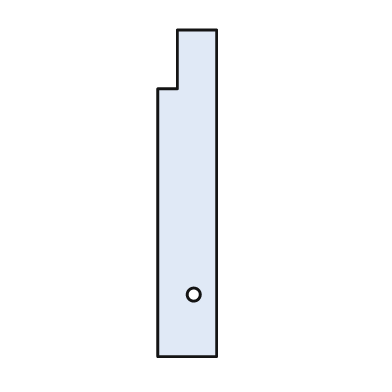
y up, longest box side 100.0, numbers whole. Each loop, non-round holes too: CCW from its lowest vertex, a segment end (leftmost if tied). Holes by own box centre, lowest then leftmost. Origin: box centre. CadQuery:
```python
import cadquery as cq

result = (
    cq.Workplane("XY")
    .moveTo(-9.0, -50.0)
    .lineTo(9.0, -50.0)
    .lineTo(9.0, 50.0)
    .lineTo(-3.0, 50.0)
    .lineTo(-3.0, 32.0)
    .lineTo(-9.0, 32.0)
    .close()
    .moveTo(2.0, -31.0)
    .circle(2.0)
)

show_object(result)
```